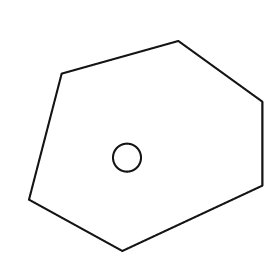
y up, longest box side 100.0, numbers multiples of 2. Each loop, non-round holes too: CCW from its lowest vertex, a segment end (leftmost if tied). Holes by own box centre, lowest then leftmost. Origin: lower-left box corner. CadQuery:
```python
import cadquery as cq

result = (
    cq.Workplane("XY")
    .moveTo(40.0, 0.0)
    .lineTo(100.0, 28.0)
    .lineTo(100.0, 64.0)
    .lineTo(64.0, 90.0)
    .lineTo(14.0, 76.0)
    .lineTo(0.0, 22.0)
    .close()
    .moveTo(42.0, 40.0)
    .circle(6.0)
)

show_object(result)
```